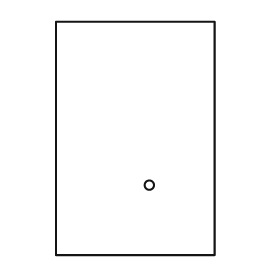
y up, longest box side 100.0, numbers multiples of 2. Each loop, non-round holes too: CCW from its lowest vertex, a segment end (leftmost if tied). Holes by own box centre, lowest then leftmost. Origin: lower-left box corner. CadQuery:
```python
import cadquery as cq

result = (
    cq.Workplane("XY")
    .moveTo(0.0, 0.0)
    .lineTo(68.0, 0.0)
    .lineTo(68.0, 100.0)
    .lineTo(0.0, 100.0)
    .close()
    .moveTo(40.0, 30.0)
    .circle(2.0)
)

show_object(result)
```